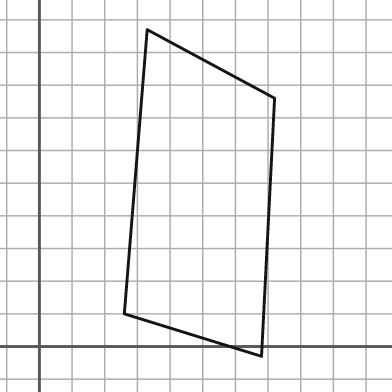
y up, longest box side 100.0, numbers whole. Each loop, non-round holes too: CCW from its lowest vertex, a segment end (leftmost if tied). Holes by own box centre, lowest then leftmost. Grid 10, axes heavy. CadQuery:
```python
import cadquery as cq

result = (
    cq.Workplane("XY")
    .moveTo(68.0, -3.0)
    .lineTo(72.0, 76.0)
    .lineTo(33.0, 97.0)
    .lineTo(26.0, 10.0)
    .close()
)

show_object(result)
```